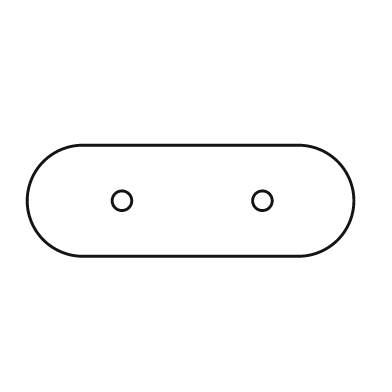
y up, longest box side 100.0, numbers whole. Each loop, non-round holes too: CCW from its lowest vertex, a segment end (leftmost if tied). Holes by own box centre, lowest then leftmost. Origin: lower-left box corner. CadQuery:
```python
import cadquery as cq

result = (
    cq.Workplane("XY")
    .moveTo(17.0, 0.0)
    .lineTo(83.0, 0.0)
    .threePointArc((100.0, 17.0), (83.0, 34.0))
    .lineTo(17.0, 34.0)
    .threePointArc((0.0, 17.0), (17.0, 0.0))
    .close()
    .moveTo(29.0, 17.0)
    .circle(3.0)
    .moveTo(72.0, 17.0)
    .circle(3.0)
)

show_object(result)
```